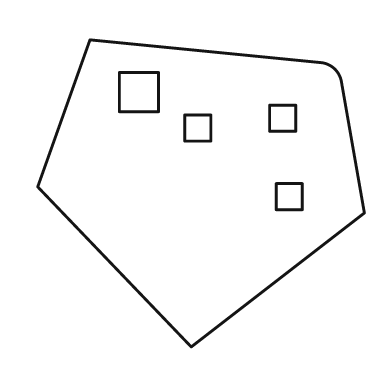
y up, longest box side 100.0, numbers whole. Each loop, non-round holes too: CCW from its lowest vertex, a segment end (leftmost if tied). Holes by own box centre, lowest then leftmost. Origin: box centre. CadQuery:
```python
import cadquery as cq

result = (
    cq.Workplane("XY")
    .moveTo(-3.0, -47.0)
    .lineTo(50.0, -6.0)
    .lineTo(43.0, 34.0)
    .threePointArc((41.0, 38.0), (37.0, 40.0))
    .lineTo(-34.0, 47.0)
    .lineTo(-50.0, 2.0)
    .close()
    .moveTo(23.0, -5.0)
    .lineTo(31.0, -5.0)
    .lineTo(31.0, 3.0)
    .lineTo(23.0, 3.0)
    .close()
    .moveTo(-5.0, 16.0)
    .lineTo(3.0, 16.0)
    .lineTo(3.0, 24.0)
    .lineTo(-5.0, 24.0)
    .close()
    .moveTo(21.0, 19.0)
    .lineTo(29.0, 19.0)
    .lineTo(29.0, 27.0)
    .lineTo(21.0, 27.0)
    .close()
    .moveTo(-25.0, 25.0)
    .lineTo(-13.0, 25.0)
    .lineTo(-13.0, 37.0)
    .lineTo(-25.0, 37.0)
    .close()
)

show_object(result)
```